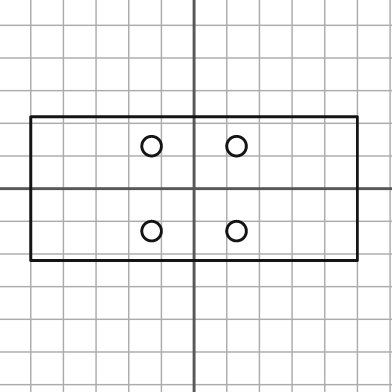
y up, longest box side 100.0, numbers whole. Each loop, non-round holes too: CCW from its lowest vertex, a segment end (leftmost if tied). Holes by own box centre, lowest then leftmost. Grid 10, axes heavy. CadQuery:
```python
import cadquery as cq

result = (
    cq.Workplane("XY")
    .moveTo(-50.0, -22.0)
    .lineTo(50.0, -22.0)
    .lineTo(50.0, 22.0)
    .lineTo(-50.0, 22.0)
    .close()
    .moveTo(-13.0, -13.0)
    .circle(3.0)
    .moveTo(13.0, -13.0)
    .circle(3.0)
    .moveTo(-13.0, 13.0)
    .circle(3.0)
    .moveTo(13.0, 13.0)
    .circle(3.0)
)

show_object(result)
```